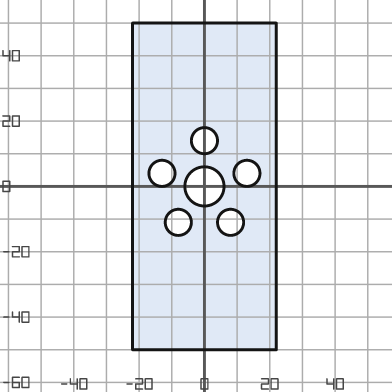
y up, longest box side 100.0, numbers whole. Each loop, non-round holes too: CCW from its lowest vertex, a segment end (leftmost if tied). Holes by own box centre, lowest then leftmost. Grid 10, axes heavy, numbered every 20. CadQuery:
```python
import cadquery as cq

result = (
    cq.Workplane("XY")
    .moveTo(-22.0, -50.0)
    .lineTo(22.0, -50.0)
    .lineTo(22.0, 50.0)
    .lineTo(-22.0, 50.0)
    .close()
    .moveTo(-8.0, -11.0)
    .circle(4.0)
    .moveTo(8.0, -11.0)
    .circle(4.0)
    .moveTo(0.0, 0.0)
    .circle(6.0)
    .moveTo(-13.0, 4.0)
    .circle(4.0)
    .moveTo(13.0, 4.0)
    .circle(4.0)
    .moveTo(0.0, 14.0)
    .circle(4.0)
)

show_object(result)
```